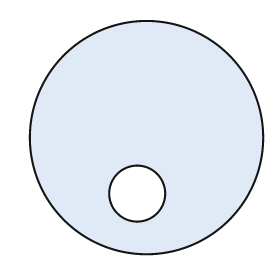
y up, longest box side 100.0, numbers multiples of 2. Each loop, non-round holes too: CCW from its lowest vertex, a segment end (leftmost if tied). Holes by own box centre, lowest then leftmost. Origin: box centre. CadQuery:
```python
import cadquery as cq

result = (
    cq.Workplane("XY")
    .moveTo(0.0, 0.0)
    .circle(50.0)
    .moveTo(-4.0, -24.0)
    .circle(12.0)
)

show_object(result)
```